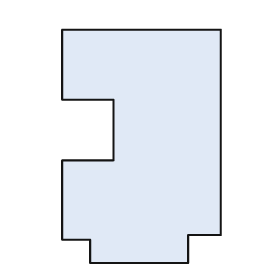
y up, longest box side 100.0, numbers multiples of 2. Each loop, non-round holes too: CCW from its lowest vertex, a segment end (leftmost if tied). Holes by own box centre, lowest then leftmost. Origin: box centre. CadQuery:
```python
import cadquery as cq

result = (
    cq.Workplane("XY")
    .moveTo(-22.0, -50.0)
    .lineTo(20.0, -50.0)
    .lineTo(20.0, -38.0)
    .lineTo(34.0, -38.0)
    .lineTo(34.0, 50.0)
    .lineTo(-34.0, 50.0)
    .lineTo(-34.0, 20.0)
    .lineTo(-12.0, 20.0)
    .lineTo(-12.0, -6.0)
    .lineTo(-34.0, -6.0)
    .lineTo(-34.0, -40.0)
    .lineTo(-22.0, -40.0)
    .close()
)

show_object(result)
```